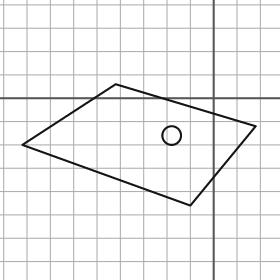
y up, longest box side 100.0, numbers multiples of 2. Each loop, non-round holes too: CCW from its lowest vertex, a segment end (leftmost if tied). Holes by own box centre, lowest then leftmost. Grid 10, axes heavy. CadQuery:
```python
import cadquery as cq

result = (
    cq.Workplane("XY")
    .moveTo(-10.0, -46.0)
    .lineTo(18.0, -12.0)
    .lineTo(-42.0, 6.0)
    .lineTo(-82.0, -20.0)
    .close()
    .moveTo(-18.0, -16.0)
    .circle(4.0)
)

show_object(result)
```